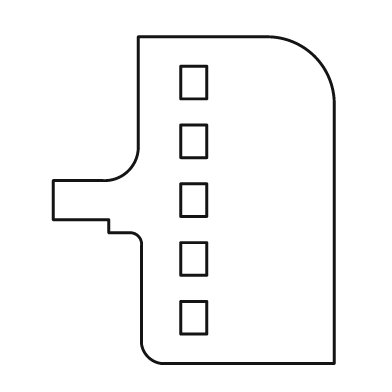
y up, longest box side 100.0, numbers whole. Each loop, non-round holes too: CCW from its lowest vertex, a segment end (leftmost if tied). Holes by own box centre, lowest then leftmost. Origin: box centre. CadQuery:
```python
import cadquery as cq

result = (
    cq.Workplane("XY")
    .moveTo(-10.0, -50.0)
    .lineTo(43.0, -50.0)
    .lineTo(43.0, 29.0)
    .threePointArc((37.0, 44.0), (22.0, 50.0))
    .lineTo(-17.0, 50.0)
    .lineTo(-17.0, 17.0)
    .threePointArc((-20.0, 9.0), (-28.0, 6.0))
    .lineTo(-43.0, 6.0)
    .lineTo(-43.0, -6.0)
    .lineTo(-26.0, -6.0)
    .lineTo(-26.0, -10.0)
    .lineTo(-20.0, -10.0)
    .threePointArc((-17.0, -11.0), (-16.0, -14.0))
    .lineTo(-16.0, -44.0)
    .threePointArc((-14.0, -48.0), (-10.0, -50.0))
    .close()
    .moveTo(-4.0, -41.0)
    .lineTo(4.0, -41.0)
    .lineTo(4.0, -31.0)
    .lineTo(-4.0, -31.0)
    .close()
    .moveTo(-4.0, -23.0)
    .lineTo(4.0, -23.0)
    .lineTo(4.0, -13.0)
    .lineTo(-4.0, -13.0)
    .close()
    .moveTo(-4.0, -5.0)
    .lineTo(4.0, -5.0)
    .lineTo(4.0, 5.0)
    .lineTo(-4.0, 5.0)
    .close()
    .moveTo(-4.0, 13.0)
    .lineTo(4.0, 13.0)
    .lineTo(4.0, 23.0)
    .lineTo(-4.0, 23.0)
    .close()
    .moveTo(-4.0, 31.0)
    .lineTo(4.0, 31.0)
    .lineTo(4.0, 41.0)
    .lineTo(-4.0, 41.0)
    .close()
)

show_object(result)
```